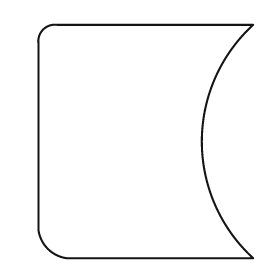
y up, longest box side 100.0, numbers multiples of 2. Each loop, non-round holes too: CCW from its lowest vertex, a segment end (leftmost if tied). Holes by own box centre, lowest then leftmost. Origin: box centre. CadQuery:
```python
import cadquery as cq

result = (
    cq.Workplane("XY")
    .moveTo(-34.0, -50.0)
    .lineTo(46.0, -50.0)
    .threePointArc((24.0, 0.0), (46.0, 50.0))
    .lineTo(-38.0, 50.0)
    .threePointArc((-44.0, 48.0), (-46.0, 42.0))
    .lineTo(-46.0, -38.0)
    .threePointArc((-42.0, -46.0), (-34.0, -50.0))
    .close()
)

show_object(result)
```